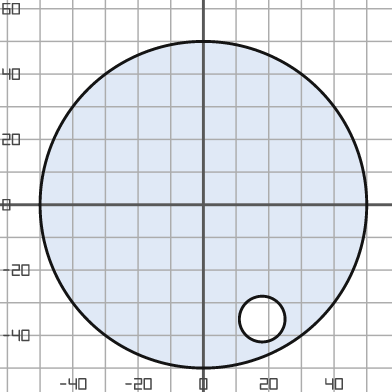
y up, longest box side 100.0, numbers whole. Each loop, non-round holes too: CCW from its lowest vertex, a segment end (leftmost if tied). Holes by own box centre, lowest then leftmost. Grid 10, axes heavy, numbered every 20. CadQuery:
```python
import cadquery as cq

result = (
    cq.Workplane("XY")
    .moveTo(0.0, 0.0)
    .circle(50.0)
    .moveTo(18.0, -35.0)
    .circle(7.0)
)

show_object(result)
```